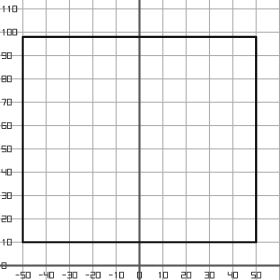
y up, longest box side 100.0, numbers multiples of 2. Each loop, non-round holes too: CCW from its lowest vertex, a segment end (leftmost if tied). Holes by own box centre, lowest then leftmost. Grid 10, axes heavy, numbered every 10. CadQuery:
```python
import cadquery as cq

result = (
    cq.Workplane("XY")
    .moveTo(-50.0, 10.0)
    .lineTo(50.0, 10.0)
    .lineTo(50.0, 98.0)
    .lineTo(-50.0, 98.0)
    .close()
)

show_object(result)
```